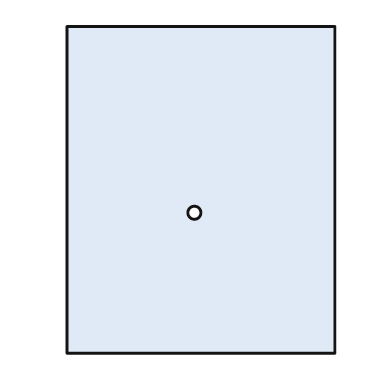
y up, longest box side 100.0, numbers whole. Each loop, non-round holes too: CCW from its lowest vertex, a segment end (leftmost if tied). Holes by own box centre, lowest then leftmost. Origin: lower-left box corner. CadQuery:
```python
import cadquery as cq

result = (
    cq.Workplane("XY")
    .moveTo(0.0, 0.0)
    .lineTo(82.0, 0.0)
    .lineTo(82.0, 100.0)
    .lineTo(0.0, 100.0)
    .close()
    .moveTo(39.0, 43.0)
    .circle(2.0)
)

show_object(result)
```